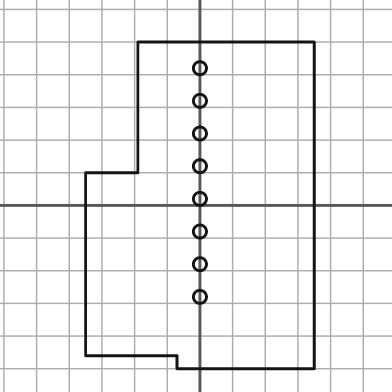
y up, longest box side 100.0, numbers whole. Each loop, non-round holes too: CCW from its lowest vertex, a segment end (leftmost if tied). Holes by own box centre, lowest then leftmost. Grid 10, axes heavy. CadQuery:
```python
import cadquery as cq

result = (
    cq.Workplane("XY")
    .moveTo(-7.0, -50.0)
    .lineTo(35.0, -50.0)
    .lineTo(35.0, 50.0)
    .lineTo(-19.0, 50.0)
    .lineTo(-19.0, 10.0)
    .lineTo(-35.0, 10.0)
    .lineTo(-35.0, -46.0)
    .lineTo(-7.0, -46.0)
    .close()
    .moveTo(0.0, -28.0)
    .circle(2.0)
    .moveTo(0.0, -18.0)
    .circle(2.0)
    .moveTo(0.0, -8.0)
    .circle(2.0)
    .moveTo(0.0, 2.0)
    .circle(2.0)
    .moveTo(0.0, 12.0)
    .circle(2.0)
    .moveTo(0.0, 22.0)
    .circle(2.0)
    .moveTo(0.0, 32.0)
    .circle(2.0)
    .moveTo(0.0, 42.0)
    .circle(2.0)
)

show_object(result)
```